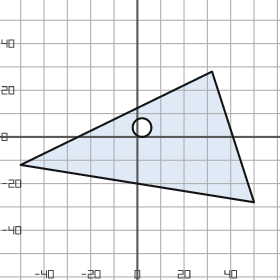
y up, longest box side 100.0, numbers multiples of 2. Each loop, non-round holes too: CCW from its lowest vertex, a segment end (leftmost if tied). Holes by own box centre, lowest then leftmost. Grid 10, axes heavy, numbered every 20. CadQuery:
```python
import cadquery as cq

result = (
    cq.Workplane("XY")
    .moveTo(50.0, -28.0)
    .lineTo(32.0, 28.0)
    .lineTo(-50.0, -12.0)
    .close()
    .moveTo(2.0, 4.0)
    .circle(4.0)
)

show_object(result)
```